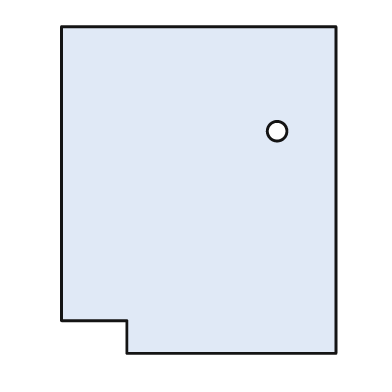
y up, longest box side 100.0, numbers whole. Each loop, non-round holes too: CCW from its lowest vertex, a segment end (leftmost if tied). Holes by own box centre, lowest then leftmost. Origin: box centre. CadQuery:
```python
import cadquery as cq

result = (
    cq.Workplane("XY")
    .moveTo(-22.0, -50.0)
    .lineTo(42.0, -50.0)
    .lineTo(42.0, 50.0)
    .lineTo(-42.0, 50.0)
    .lineTo(-42.0, -40.0)
    .lineTo(-22.0, -40.0)
    .close()
    .moveTo(24.0, 18.0)
    .circle(3.0)
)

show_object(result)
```